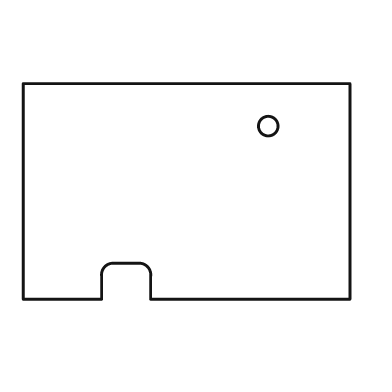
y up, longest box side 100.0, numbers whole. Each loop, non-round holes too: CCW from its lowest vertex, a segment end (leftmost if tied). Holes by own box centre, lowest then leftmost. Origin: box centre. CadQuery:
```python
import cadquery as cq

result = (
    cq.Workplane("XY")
    .moveTo(-50.0, -33.0)
    .lineTo(-26.0, -33.0)
    .lineTo(-26.0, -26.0)
    .threePointArc((-25.0, -23.0), (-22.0, -22.0))
    .lineTo(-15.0, -22.0)
    .threePointArc((-12.0, -23.0), (-11.0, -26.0))
    .lineTo(-11.0, -33.0)
    .lineTo(50.0, -33.0)
    .lineTo(50.0, 33.0)
    .lineTo(-50.0, 33.0)
    .close()
    .moveTo(25.0, 20.0)
    .circle(3.0)
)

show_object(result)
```